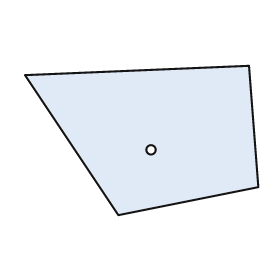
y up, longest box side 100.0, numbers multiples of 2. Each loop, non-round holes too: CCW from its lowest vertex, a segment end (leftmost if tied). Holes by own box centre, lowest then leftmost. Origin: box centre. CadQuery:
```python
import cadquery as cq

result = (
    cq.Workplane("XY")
    .moveTo(-10.0, -32.0)
    .lineTo(50.0, -20.0)
    .lineTo(46.0, 32.0)
    .lineTo(-50.0, 28.0)
    .close()
    .moveTo(4.0, -4.0)
    .circle(2.0)
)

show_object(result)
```